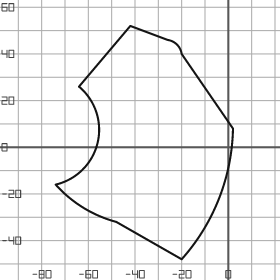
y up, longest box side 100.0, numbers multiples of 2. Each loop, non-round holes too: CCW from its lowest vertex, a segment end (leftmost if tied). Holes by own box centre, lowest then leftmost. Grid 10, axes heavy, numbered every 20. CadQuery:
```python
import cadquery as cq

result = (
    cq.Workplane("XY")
    .moveTo(-20.0, -48.0)
    .threePointArc((-4.0, -22.0), (2.0, 8.0))
    .lineTo(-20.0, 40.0)
    .threePointArc((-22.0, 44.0), (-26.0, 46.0))
    .lineTo(-42.0, 52.0)
    .lineTo(-64.0, 26.0)
    .threePointArc((-56.0, 2.0), (-74.0, -16.0))
    .threePointArc((-62.0, -26.0), (-48.0, -32.0))
    .close()
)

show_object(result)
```